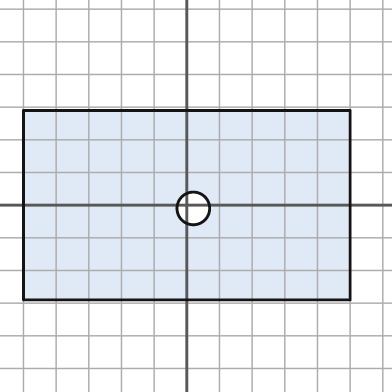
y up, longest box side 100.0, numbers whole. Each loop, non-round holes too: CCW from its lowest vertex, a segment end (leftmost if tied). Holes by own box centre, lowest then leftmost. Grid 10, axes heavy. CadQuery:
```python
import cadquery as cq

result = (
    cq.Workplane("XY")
    .moveTo(-50.0, -29.0)
    .lineTo(50.0, -29.0)
    .lineTo(50.0, 29.0)
    .lineTo(-50.0, 29.0)
    .close()
    .moveTo(2.0, -1.0)
    .circle(5.0)
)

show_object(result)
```